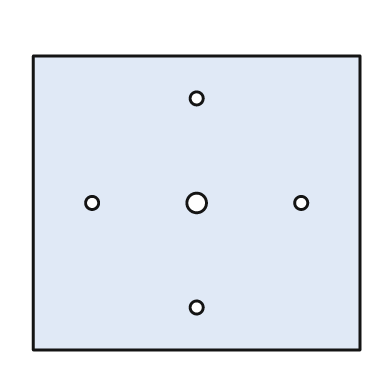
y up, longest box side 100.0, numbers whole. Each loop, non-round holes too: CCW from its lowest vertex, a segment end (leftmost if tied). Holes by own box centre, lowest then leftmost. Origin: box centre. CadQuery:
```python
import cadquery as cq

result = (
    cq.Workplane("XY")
    .moveTo(-50.0, -45.0)
    .lineTo(50.0, -45.0)
    .lineTo(50.0, 45.0)
    .lineTo(-50.0, 45.0)
    .close()
    .moveTo(0.0, -32.0)
    .circle(2.0)
    .moveTo(-32.0, 0.0)
    .circle(2.0)
    .moveTo(0.0, 0.0)
    .circle(3.0)
    .moveTo(32.0, 0.0)
    .circle(2.0)
    .moveTo(0.0, 32.0)
    .circle(2.0)
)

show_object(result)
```